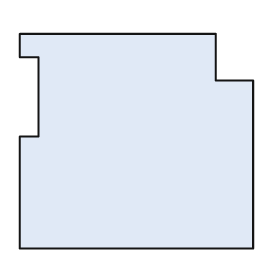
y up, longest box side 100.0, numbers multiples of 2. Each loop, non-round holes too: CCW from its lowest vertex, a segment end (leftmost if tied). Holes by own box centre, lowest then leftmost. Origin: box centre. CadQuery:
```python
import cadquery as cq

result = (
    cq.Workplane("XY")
    .moveTo(-50.0, -46.0)
    .lineTo(50.0, -46.0)
    .lineTo(50.0, 26.0)
    .lineTo(34.0, 26.0)
    .lineTo(34.0, 46.0)
    .lineTo(-50.0, 46.0)
    .lineTo(-50.0, 36.0)
    .lineTo(-42.0, 36.0)
    .lineTo(-42.0, 2.0)
    .lineTo(-50.0, 2.0)
    .close()
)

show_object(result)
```